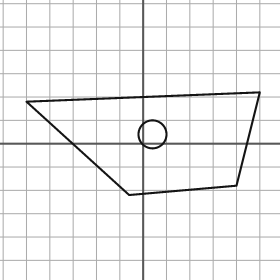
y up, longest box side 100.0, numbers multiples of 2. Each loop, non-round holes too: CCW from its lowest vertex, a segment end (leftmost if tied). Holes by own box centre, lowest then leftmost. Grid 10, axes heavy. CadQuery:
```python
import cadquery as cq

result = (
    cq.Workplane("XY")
    .moveTo(-6.0, -22.0)
    .lineTo(40.0, -18.0)
    .lineTo(50.0, 22.0)
    .lineTo(-50.0, 18.0)
    .close()
    .moveTo(4.0, 4.0)
    .circle(6.0)
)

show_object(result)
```